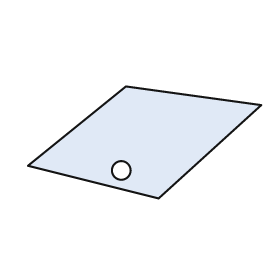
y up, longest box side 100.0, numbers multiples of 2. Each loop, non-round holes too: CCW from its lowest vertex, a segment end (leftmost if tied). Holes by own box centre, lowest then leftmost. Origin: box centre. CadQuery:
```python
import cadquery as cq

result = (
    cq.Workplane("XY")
    .moveTo(6.0, -24.0)
    .lineTo(50.0, 16.0)
    .lineTo(-8.0, 24.0)
    .lineTo(-50.0, -10.0)
    .close()
    .moveTo(-10.0, -12.0)
    .circle(4.0)
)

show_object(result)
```